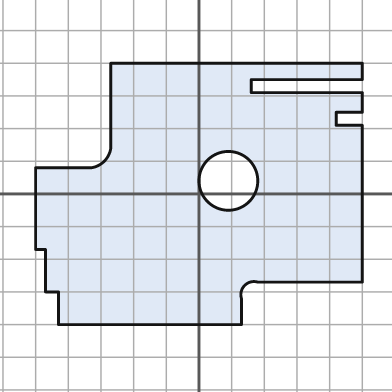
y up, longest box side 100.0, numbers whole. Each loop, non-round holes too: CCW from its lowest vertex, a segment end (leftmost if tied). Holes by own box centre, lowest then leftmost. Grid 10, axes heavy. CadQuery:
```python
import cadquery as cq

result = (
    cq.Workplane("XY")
    .moveTo(-43.0, -40.0)
    .lineTo(13.0, -40.0)
    .lineTo(13.0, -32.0)
    .threePointArc((14.0, -28.0), (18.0, -27.0))
    .lineTo(50.0, -27.0)
    .lineTo(50.0, 21.0)
    .lineTo(42.0, 21.0)
    .lineTo(42.0, 25.0)
    .lineTo(50.0, 25.0)
    .lineTo(50.0, 31.0)
    .lineTo(16.0, 31.0)
    .lineTo(16.0, 35.0)
    .lineTo(50.0, 35.0)
    .lineTo(50.0, 40.0)
    .lineTo(-27.0, 40.0)
    .lineTo(-27.0, 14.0)
    .threePointArc((-29.0, 10.0), (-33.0, 8.0))
    .lineTo(-50.0, 8.0)
    .lineTo(-50.0, -17.0)
    .lineTo(-47.0, -17.0)
    .lineTo(-47.0, -30.0)
    .lineTo(-43.0, -30.0)
    .close()
    .moveTo(9.0, 4.0)
    .circle(9.0)
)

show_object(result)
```